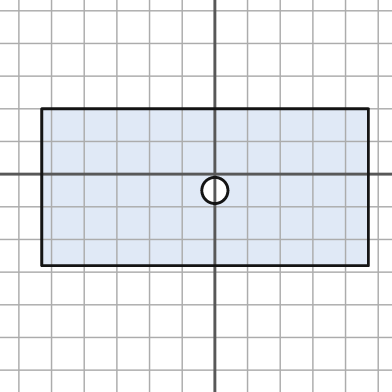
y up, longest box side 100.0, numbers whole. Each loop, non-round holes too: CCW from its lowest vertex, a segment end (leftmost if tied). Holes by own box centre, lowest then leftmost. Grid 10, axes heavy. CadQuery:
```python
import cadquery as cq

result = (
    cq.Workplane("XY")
    .moveTo(-53.0, -28.0)
    .lineTo(47.0, -28.0)
    .lineTo(47.0, 20.0)
    .lineTo(-53.0, 20.0)
    .close()
    .moveTo(0.0, -5.0)
    .circle(4.0)
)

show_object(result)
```